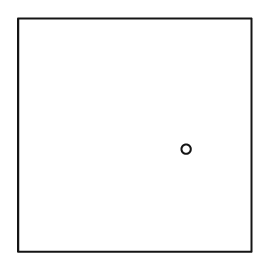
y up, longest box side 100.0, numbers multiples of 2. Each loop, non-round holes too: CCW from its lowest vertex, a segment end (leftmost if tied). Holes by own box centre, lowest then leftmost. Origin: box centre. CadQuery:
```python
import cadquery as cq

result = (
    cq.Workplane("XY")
    .moveTo(-50.0, -50.0)
    .lineTo(50.0, -50.0)
    .lineTo(50.0, 50.0)
    .lineTo(-50.0, 50.0)
    .close()
    .moveTo(22.0, -6.0)
    .circle(2.0)
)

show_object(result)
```